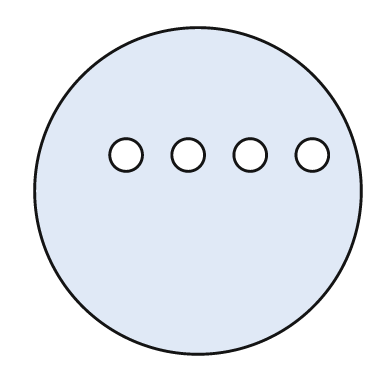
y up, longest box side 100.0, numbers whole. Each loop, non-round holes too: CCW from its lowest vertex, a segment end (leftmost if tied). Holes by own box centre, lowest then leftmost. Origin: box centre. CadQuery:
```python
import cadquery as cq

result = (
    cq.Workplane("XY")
    .moveTo(0.0, 0.0)
    .circle(50.0)
    .moveTo(-22.0, 11.0)
    .circle(5.0)
    .moveTo(-3.0, 11.0)
    .circle(5.0)
    .moveTo(16.0, 11.0)
    .circle(5.0)
    .moveTo(35.0, 11.0)
    .circle(5.0)
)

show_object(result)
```